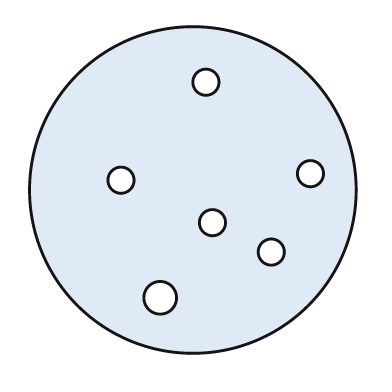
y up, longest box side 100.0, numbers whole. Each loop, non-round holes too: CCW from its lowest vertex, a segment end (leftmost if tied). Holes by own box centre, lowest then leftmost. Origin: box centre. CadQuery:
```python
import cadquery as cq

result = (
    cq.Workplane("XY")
    .moveTo(0.0, 0.0)
    .circle(50.0)
    .moveTo(-10.0, -33.0)
    .circle(5.0)
    .moveTo(24.0, -19.0)
    .circle(4.0)
    .moveTo(6.0, -10.0)
    .circle(4.0)
    .moveTo(-22.0, 3.0)
    .circle(4.0)
    .moveTo(36.0, 5.0)
    .circle(4.0)
    .moveTo(4.0, 33.0)
    .circle(4.0)
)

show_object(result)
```